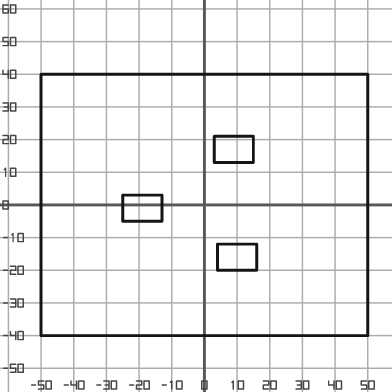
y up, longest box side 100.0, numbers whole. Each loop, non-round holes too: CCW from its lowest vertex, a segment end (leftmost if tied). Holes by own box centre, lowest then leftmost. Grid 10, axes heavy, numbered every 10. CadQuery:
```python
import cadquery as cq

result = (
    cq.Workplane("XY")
    .moveTo(-50.0, -40.0)
    .lineTo(50.0, -40.0)
    .lineTo(50.0, 40.0)
    .lineTo(-50.0, 40.0)
    .close()
    .moveTo(4.0, -20.0)
    .lineTo(16.0, -20.0)
    .lineTo(16.0, -12.0)
    .lineTo(4.0, -12.0)
    .close()
    .moveTo(-25.0, -5.0)
    .lineTo(-13.0, -5.0)
    .lineTo(-13.0, 3.0)
    .lineTo(-25.0, 3.0)
    .close()
    .moveTo(3.0, 13.0)
    .lineTo(15.0, 13.0)
    .lineTo(15.0, 21.0)
    .lineTo(3.0, 21.0)
    .close()
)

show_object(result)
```